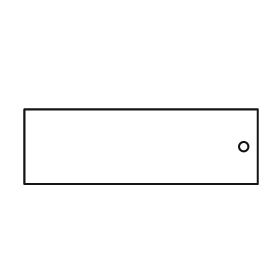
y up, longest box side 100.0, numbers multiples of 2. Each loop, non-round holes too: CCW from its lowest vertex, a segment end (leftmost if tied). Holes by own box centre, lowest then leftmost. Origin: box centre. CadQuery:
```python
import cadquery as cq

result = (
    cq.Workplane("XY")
    .moveTo(-50.0, -16.0)
    .lineTo(50.0, -16.0)
    .lineTo(50.0, 16.0)
    .lineTo(-50.0, 16.0)
    .close()
    .moveTo(44.0, 0.0)
    .circle(2.0)
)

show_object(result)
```